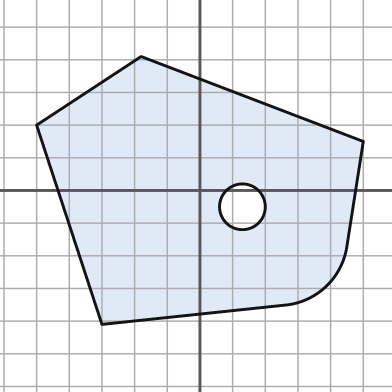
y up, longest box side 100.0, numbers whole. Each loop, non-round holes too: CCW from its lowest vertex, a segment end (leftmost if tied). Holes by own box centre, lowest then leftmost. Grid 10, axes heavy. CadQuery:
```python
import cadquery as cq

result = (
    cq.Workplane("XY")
    .moveTo(-30.0, -41.0)
    .lineTo(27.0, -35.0)
    .threePointArc((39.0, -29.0), (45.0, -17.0))
    .lineTo(50.0, 15.0)
    .lineTo(-18.0, 41.0)
    .lineTo(-50.0, 20.0)
    .close()
    .moveTo(13.0, -5.0)
    .circle(7.0)
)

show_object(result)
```